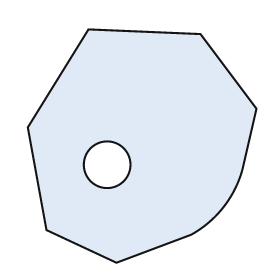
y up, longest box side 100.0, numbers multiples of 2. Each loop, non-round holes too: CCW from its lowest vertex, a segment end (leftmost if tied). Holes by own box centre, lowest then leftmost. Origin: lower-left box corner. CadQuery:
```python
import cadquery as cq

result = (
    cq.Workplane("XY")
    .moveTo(38.0, 0.0)
    .lineTo(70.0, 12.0)
    .threePointArc((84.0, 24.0), (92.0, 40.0))
    .lineTo(98.0, 66.0)
    .lineTo(74.0, 98.0)
    .lineTo(26.0, 100.0)
    .lineTo(0.0, 58.0)
    .lineTo(8.0, 14.0)
    .close()
    .moveTo(34.0, 42.0)
    .circle(10.0)
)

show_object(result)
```